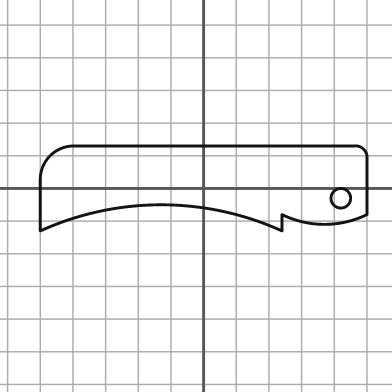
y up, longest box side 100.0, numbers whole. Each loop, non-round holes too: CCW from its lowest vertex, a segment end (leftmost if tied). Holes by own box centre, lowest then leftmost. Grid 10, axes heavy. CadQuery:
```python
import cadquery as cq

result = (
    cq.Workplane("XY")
    .moveTo(-50.0, -13.0)
    .threePointArc((-13.0, -5.0), (24.0, -13.0))
    .lineTo(24.0, -8.0)
    .threePointArc((37.0, -11.0), (50.0, -8.0))
    .lineTo(50.0, 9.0)
    .threePointArc((49.0, 12.0), (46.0, 13.0))
    .lineTo(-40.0, 13.0)
    .threePointArc((-47.0, 10.0), (-50.0, 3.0))
    .close()
    .moveTo(42.0, -3.0)
    .circle(3.0)
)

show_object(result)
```